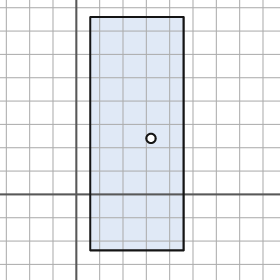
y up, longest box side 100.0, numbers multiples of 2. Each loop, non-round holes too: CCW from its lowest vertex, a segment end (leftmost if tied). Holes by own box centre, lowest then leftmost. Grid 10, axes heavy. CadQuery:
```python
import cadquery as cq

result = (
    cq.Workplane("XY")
    .moveTo(6.0, -24.0)
    .lineTo(46.0, -24.0)
    .lineTo(46.0, 76.0)
    .lineTo(6.0, 76.0)
    .close()
    .moveTo(32.0, 24.0)
    .circle(2.0)
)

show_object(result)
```